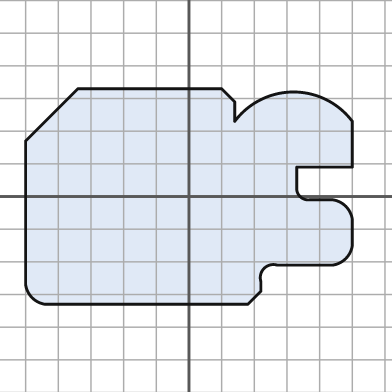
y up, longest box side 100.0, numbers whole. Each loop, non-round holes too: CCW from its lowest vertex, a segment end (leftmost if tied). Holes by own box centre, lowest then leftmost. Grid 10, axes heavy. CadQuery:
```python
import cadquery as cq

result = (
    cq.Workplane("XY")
    .moveTo(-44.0, -33.0)
    .lineTo(18.0, -33.0)
    .lineTo(22.0, -29.0)
    .lineTo(22.0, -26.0)
    .threePointArc((23.0, -22.0), (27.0, -21.0))
    .lineTo(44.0, -21.0)
    .threePointArc((48.0, -19.0), (50.0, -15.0))
    .lineTo(50.0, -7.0)
    .threePointArc((48.0, -3.0), (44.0, -1.0))
    .lineTo(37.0, -1.0)
    .threePointArc((34.0, 0.0), (33.0, 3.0))
    .lineTo(33.0, 9.0)
    .lineTo(50.0, 9.0)
    .lineTo(50.0, 23.0)
    .threePointArc((32.0, 32.0), (14.0, 23.0))
    .lineTo(14.0, 29.0)
    .lineTo(10.0, 33.0)
    .lineTo(-34.0, 33.0)
    .lineTo(-50.0, 17.0)
    .lineTo(-50.0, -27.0)
    .threePointArc((-48.0, -31.0), (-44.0, -33.0))
    .close()
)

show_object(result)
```